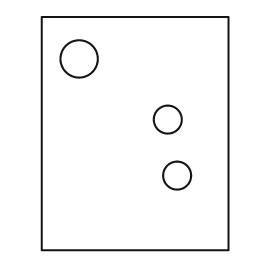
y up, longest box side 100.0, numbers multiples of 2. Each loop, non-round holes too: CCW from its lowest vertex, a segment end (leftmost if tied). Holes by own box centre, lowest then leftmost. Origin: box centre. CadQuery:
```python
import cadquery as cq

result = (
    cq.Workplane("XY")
    .moveTo(-40.0, -50.0)
    .lineTo(40.0, -50.0)
    .lineTo(40.0, 50.0)
    .lineTo(-40.0, 50.0)
    .close()
    .moveTo(18.0, -18.0)
    .circle(6.0)
    .moveTo(14.0, 6.0)
    .circle(6.0)
    .moveTo(-24.0, 32.0)
    .circle(8.0)
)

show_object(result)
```